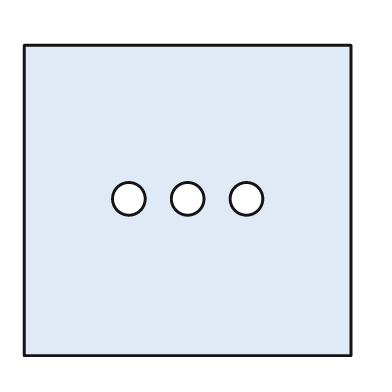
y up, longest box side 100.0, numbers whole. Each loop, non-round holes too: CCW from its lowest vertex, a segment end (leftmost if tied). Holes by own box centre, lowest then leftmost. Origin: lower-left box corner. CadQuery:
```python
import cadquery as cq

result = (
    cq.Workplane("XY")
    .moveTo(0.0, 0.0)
    .lineTo(100.0, 0.0)
    .lineTo(100.0, 95.0)
    .lineTo(0.0, 95.0)
    .close()
    .moveTo(32.0, 48.0)
    .circle(5.0)
    .moveTo(50.0, 48.0)
    .circle(5.0)
    .moveTo(68.0, 48.0)
    .circle(5.0)
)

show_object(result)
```